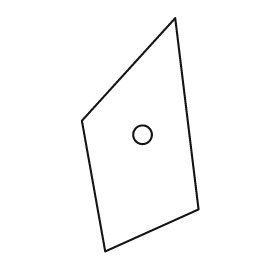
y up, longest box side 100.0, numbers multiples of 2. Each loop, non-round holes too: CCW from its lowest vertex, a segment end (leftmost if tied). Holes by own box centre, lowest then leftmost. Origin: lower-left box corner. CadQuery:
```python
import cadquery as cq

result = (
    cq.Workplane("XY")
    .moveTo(10.0, 0.0)
    .lineTo(50.0, 18.0)
    .lineTo(40.0, 100.0)
    .lineTo(0.0, 56.0)
    .close()
    .moveTo(26.0, 50.0)
    .circle(4.0)
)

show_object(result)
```